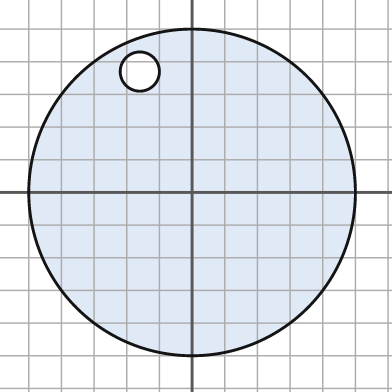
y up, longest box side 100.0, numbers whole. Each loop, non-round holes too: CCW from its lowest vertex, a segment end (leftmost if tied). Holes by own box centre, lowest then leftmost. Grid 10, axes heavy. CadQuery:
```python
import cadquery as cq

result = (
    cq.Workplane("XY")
    .moveTo(0.0, 0.0)
    .circle(50.0)
    .moveTo(-16.0, 37.0)
    .circle(6.0)
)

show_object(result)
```